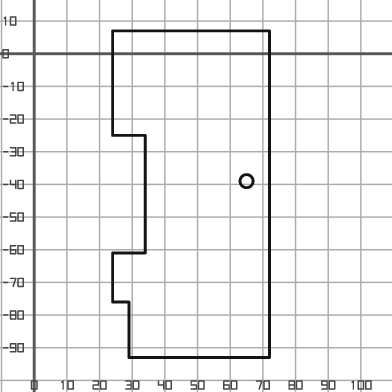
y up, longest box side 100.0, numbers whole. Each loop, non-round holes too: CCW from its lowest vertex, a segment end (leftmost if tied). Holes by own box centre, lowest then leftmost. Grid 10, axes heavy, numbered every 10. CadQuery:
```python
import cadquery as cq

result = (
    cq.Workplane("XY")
    .moveTo(29.0, -93.0)
    .lineTo(72.0, -93.0)
    .lineTo(72.0, 7.0)
    .lineTo(24.0, 7.0)
    .lineTo(24.0, -25.0)
    .lineTo(34.0, -25.0)
    .lineTo(34.0, -61.0)
    .lineTo(24.0, -61.0)
    .lineTo(24.0, -76.0)
    .lineTo(29.0, -76.0)
    .close()
    .moveTo(65.0, -39.0)
    .circle(2.0)
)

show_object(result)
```